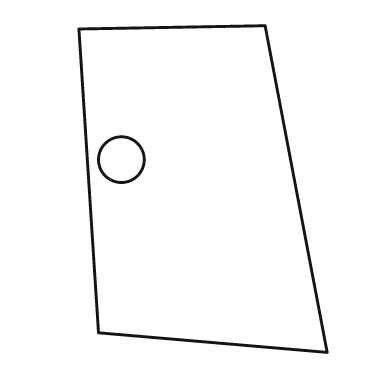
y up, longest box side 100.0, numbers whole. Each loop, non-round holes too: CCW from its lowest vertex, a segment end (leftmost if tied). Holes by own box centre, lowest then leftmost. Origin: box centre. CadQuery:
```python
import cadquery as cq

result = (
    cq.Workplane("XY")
    .moveTo(38.0, -50.0)
    .lineTo(19.0, 50.0)
    .lineTo(-38.0, 49.0)
    .lineTo(-32.0, -44.0)
    .close()
    .moveTo(-25.0, 9.0)
    .circle(7.0)
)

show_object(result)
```